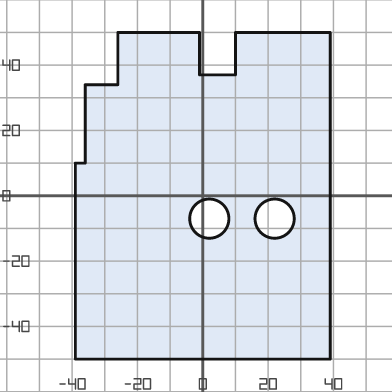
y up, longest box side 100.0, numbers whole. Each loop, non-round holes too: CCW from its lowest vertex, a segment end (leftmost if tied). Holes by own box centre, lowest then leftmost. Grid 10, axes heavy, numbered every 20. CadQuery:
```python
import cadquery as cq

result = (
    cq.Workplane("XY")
    .moveTo(-39.0, -50.0)
    .lineTo(39.0, -50.0)
    .lineTo(39.0, 50.0)
    .lineTo(10.0, 50.0)
    .lineTo(10.0, 37.0)
    .lineTo(-1.0, 37.0)
    .lineTo(-1.0, 50.0)
    .lineTo(-26.0, 50.0)
    .lineTo(-26.0, 34.0)
    .lineTo(-36.0, 34.0)
    .lineTo(-36.0, 10.0)
    .lineTo(-39.0, 10.0)
    .close()
    .moveTo(2.0, -7.0)
    .circle(6.0)
    .moveTo(22.0, -7.0)
    .circle(6.0)
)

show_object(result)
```